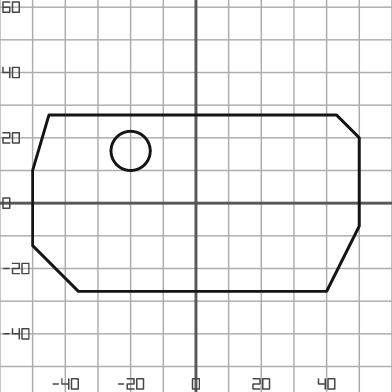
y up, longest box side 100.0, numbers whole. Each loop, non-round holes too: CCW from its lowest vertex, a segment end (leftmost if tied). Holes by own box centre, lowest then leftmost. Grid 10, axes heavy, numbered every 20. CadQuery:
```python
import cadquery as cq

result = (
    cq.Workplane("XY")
    .moveTo(-36.0, -27.0)
    .lineTo(40.0, -27.0)
    .lineTo(50.0, -7.0)
    .lineTo(50.0, 20.0)
    .lineTo(43.0, 27.0)
    .lineTo(-45.0, 27.0)
    .lineTo(-50.0, 10.0)
    .lineTo(-50.0, -13.0)
    .close()
    .moveTo(-20.0, 16.0)
    .circle(6.0)
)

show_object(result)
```